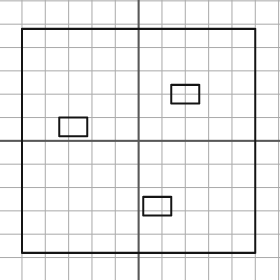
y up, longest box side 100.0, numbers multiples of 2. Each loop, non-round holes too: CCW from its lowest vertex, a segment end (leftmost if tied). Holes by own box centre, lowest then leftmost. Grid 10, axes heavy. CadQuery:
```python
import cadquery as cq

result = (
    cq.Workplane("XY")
    .moveTo(-50.0, -48.0)
    .lineTo(50.0, -48.0)
    .lineTo(50.0, 48.0)
    .lineTo(-50.0, 48.0)
    .close()
    .moveTo(2.0, -32.0)
    .lineTo(14.0, -32.0)
    .lineTo(14.0, -24.0)
    .lineTo(2.0, -24.0)
    .close()
    .moveTo(-34.0, 2.0)
    .lineTo(-22.0, 2.0)
    .lineTo(-22.0, 10.0)
    .lineTo(-34.0, 10.0)
    .close()
    .moveTo(14.0, 16.0)
    .lineTo(26.0, 16.0)
    .lineTo(26.0, 24.0)
    .lineTo(14.0, 24.0)
    .close()
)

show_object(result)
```